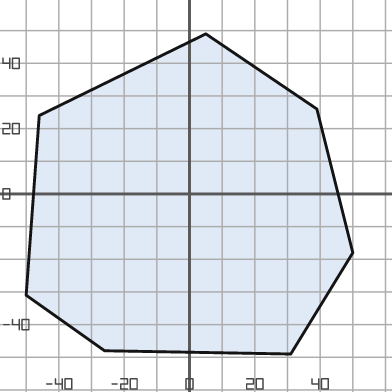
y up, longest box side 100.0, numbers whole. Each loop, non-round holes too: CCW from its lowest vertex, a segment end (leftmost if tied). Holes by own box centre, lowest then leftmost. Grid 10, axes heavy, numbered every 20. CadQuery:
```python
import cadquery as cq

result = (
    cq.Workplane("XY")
    .moveTo(31.0, -49.0)
    .lineTo(50.0, -18.0)
    .lineTo(39.0, 26.0)
    .lineTo(5.0, 49.0)
    .lineTo(-46.0, 24.0)
    .lineTo(-50.0, -31.0)
    .lineTo(-26.0, -48.0)
    .close()
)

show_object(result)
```